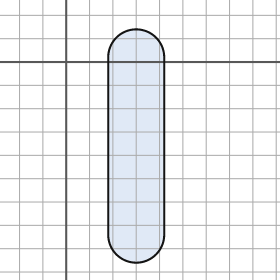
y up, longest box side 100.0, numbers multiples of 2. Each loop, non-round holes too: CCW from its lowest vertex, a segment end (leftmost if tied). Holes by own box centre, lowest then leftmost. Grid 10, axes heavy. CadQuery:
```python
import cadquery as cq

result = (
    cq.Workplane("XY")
    .moveTo(18.0, -74.0)
    .threePointArc((30.0, -86.0), (42.0, -74.0))
    .lineTo(42.0, 2.0)
    .threePointArc((30.0, 14.0), (18.0, 2.0))
    .close()
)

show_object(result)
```